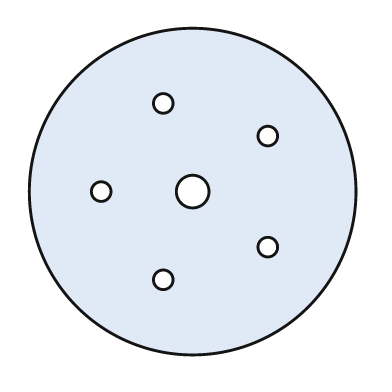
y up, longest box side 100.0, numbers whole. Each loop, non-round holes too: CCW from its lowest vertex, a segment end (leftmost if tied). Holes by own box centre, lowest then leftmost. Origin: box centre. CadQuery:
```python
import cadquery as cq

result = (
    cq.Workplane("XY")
    .moveTo(0.0, 0.0)
    .circle(50.0)
    .moveTo(-9.0, -27.0)
    .circle(3.0)
    .moveTo(23.0, -17.0)
    .circle(3.0)
    .moveTo(-28.0, 0.0)
    .circle(3.0)
    .moveTo(0.0, 0.0)
    .circle(5.0)
    .moveTo(23.0, 17.0)
    .circle(3.0)
    .moveTo(-9.0, 27.0)
    .circle(3.0)
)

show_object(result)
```